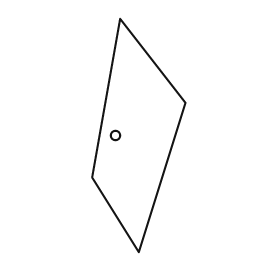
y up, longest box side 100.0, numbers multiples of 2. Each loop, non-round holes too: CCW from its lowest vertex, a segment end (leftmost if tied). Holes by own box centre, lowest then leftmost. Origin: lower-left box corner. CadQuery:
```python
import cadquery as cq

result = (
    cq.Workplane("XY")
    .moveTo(20.0, 0.0)
    .lineTo(40.0, 64.0)
    .lineTo(12.0, 100.0)
    .lineTo(0.0, 32.0)
    .close()
    .moveTo(10.0, 50.0)
    .circle(2.0)
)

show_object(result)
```